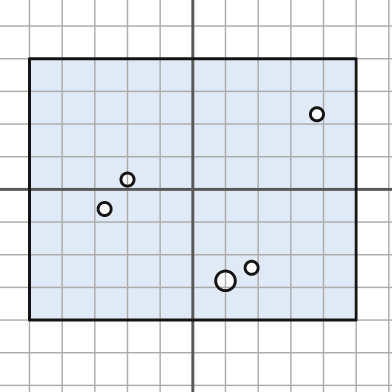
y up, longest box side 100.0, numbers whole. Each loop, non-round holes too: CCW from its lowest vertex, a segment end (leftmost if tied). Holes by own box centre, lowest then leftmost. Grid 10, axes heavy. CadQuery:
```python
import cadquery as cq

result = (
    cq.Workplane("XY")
    .moveTo(-50.0, -40.0)
    .lineTo(50.0, -40.0)
    .lineTo(50.0, 40.0)
    .lineTo(-50.0, 40.0)
    .close()
    .moveTo(10.0, -28.0)
    .circle(3.0)
    .moveTo(18.0, -24.0)
    .circle(2.0)
    .moveTo(-27.0, -6.0)
    .circle(2.0)
    .moveTo(-20.0, 3.0)
    .circle(2.0)
    .moveTo(38.0, 23.0)
    .circle(2.0)
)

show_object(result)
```